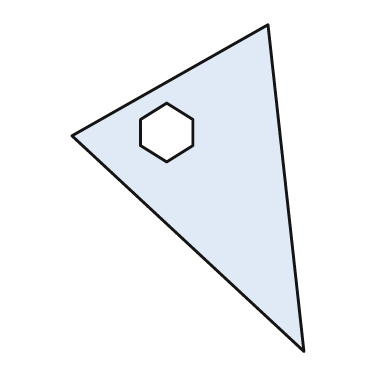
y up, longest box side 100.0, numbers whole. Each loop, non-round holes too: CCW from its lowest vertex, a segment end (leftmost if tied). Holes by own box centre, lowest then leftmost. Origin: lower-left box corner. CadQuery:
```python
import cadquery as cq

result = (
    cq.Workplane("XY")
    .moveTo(71.0, 0.0)
    .lineTo(60.0, 100.0)
    .lineTo(0.0, 66.0)
    .close()
    .moveTo(29.0, 58.0)
    .lineTo(37.0, 63.0)
    .lineTo(37.0, 71.0)
    .lineTo(29.0, 76.0)
    .lineTo(21.0, 71.0)
    .lineTo(21.0, 63.0)
    .close()
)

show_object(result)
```